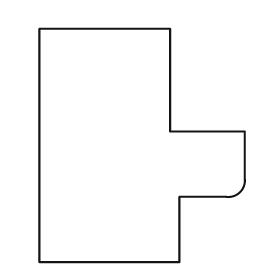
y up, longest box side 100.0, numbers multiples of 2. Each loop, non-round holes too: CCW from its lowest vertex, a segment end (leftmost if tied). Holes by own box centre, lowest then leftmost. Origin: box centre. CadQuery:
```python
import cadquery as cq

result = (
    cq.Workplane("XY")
    .moveTo(-44.0, -50.0)
    .lineTo(16.0, -50.0)
    .lineTo(16.0, -22.0)
    .lineTo(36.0, -22.0)
    .threePointArc((42.0, -20.0), (44.0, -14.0))
    .lineTo(44.0, 6.0)
    .lineTo(12.0, 6.0)
    .lineTo(12.0, 50.0)
    .lineTo(-44.0, 50.0)
    .close()
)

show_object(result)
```